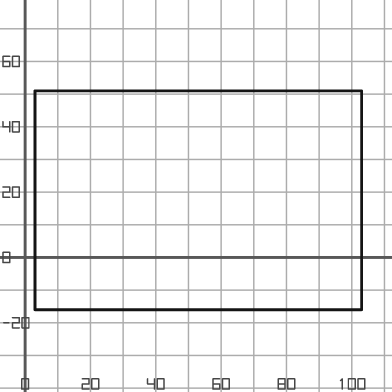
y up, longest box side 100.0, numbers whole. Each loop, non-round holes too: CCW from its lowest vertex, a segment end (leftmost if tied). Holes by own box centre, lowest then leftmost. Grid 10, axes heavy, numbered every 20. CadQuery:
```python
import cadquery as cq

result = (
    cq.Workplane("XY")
    .moveTo(3.0, -16.0)
    .lineTo(103.0, -16.0)
    .lineTo(103.0, 51.0)
    .lineTo(3.0, 51.0)
    .close()
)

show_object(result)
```